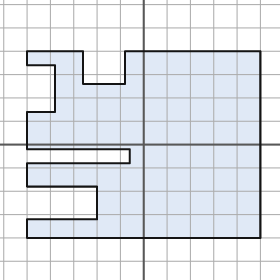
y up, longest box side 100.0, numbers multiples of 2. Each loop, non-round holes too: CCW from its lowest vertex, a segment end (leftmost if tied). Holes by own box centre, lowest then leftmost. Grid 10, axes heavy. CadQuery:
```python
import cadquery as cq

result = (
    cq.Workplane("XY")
    .moveTo(-50.0, -40.0)
    .lineTo(50.0, -40.0)
    .lineTo(50.0, 40.0)
    .lineTo(-8.0, 40.0)
    .lineTo(-8.0, 26.0)
    .lineTo(-26.0, 26.0)
    .lineTo(-26.0, 40.0)
    .lineTo(-50.0, 40.0)
    .lineTo(-50.0, 34.0)
    .lineTo(-38.0, 34.0)
    .lineTo(-38.0, 14.0)
    .lineTo(-50.0, 14.0)
    .lineTo(-50.0, -2.0)
    .lineTo(-6.0, -2.0)
    .lineTo(-6.0, -8.0)
    .lineTo(-50.0, -8.0)
    .lineTo(-50.0, -18.0)
    .lineTo(-20.0, -18.0)
    .lineTo(-20.0, -32.0)
    .lineTo(-50.0, -32.0)
    .close()
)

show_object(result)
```